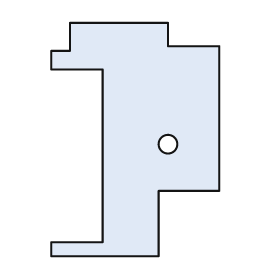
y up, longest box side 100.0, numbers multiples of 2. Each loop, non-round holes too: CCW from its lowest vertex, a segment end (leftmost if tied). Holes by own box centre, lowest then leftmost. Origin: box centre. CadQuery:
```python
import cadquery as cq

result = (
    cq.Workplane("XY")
    .moveTo(-36.0, -50.0)
    .lineTo(10.0, -50.0)
    .lineTo(10.0, -22.0)
    .lineTo(36.0, -22.0)
    .lineTo(36.0, 40.0)
    .lineTo(14.0, 40.0)
    .lineTo(14.0, 50.0)
    .lineTo(-28.0, 50.0)
    .lineTo(-28.0, 38.0)
    .lineTo(-36.0, 38.0)
    .lineTo(-36.0, 30.0)
    .lineTo(-14.0, 30.0)
    .lineTo(-14.0, -44.0)
    .lineTo(-36.0, -44.0)
    .close()
    .moveTo(14.0, -2.0)
    .circle(4.0)
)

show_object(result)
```